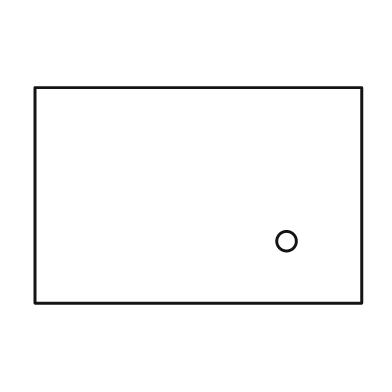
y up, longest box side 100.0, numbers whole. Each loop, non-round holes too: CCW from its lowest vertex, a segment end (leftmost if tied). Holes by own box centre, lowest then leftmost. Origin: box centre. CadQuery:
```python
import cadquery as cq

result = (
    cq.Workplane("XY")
    .moveTo(-50.0, -33.0)
    .lineTo(50.0, -33.0)
    .lineTo(50.0, 33.0)
    .lineTo(-50.0, 33.0)
    .close()
    .moveTo(27.0, -14.0)
    .circle(3.0)
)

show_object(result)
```